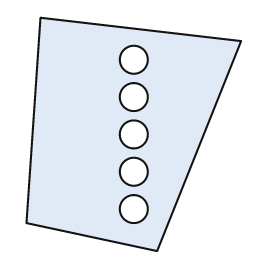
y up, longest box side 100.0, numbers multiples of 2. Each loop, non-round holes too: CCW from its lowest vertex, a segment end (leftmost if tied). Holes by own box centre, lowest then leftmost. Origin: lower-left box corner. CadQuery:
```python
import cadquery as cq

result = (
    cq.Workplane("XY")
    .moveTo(56.0, 0.0)
    .lineTo(92.0, 90.0)
    .lineTo(6.0, 100.0)
    .lineTo(0.0, 12.0)
    .close()
    .moveTo(46.0, 18.0)
    .circle(6.0)
    .moveTo(46.0, 34.0)
    .circle(6.0)
    .moveTo(46.0, 50.0)
    .circle(6.0)
    .moveTo(46.0, 66.0)
    .circle(6.0)
    .moveTo(46.0, 82.0)
    .circle(6.0)
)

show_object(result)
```